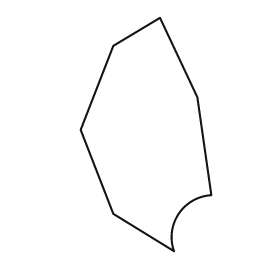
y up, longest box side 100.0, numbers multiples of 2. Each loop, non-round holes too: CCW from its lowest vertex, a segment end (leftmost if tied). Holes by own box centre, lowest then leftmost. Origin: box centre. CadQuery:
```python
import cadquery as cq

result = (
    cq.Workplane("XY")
    .moveTo(12.0, -50.0)
    .threePointArc((14.0, -34.0), (28.0, -26.0))
    .lineTo(22.0, 16.0)
    .lineTo(6.0, 50.0)
    .lineTo(-14.0, 38.0)
    .lineTo(-28.0, 2.0)
    .lineTo(-14.0, -34.0)
    .close()
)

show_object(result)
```